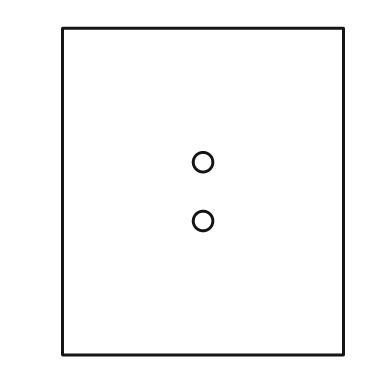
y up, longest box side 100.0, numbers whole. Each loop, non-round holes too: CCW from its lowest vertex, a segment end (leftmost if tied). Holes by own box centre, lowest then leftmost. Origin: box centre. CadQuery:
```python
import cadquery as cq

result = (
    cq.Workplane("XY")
    .moveTo(-43.0, -50.0)
    .lineTo(43.0, -50.0)
    .lineTo(43.0, 50.0)
    .lineTo(-43.0, 50.0)
    .close()
    .moveTo(0.0, -9.0)
    .circle(3.0)
    .moveTo(0.0, 9.0)
    .circle(3.0)
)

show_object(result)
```